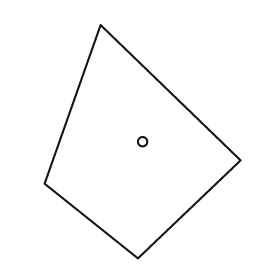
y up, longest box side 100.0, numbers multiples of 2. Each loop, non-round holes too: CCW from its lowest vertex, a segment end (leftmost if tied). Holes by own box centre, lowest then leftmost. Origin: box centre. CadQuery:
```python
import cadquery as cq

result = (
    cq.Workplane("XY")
    .moveTo(-2.0, -50.0)
    .lineTo(42.0, -8.0)
    .lineTo(-18.0, 50.0)
    .lineTo(-42.0, -18.0)
    .close()
    .moveTo(0.0, 0.0)
    .circle(2.0)
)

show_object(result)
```